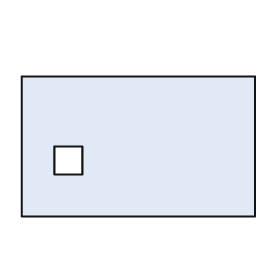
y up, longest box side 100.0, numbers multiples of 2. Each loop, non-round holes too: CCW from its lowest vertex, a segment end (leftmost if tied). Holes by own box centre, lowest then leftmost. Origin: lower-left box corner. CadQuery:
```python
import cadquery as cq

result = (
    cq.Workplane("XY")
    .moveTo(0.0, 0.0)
    .lineTo(100.0, 0.0)
    .lineTo(100.0, 60.0)
    .lineTo(0.0, 60.0)
    .close()
    .moveTo(14.0, 18.0)
    .lineTo(26.0, 18.0)
    .lineTo(26.0, 30.0)
    .lineTo(14.0, 30.0)
    .close()
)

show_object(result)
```